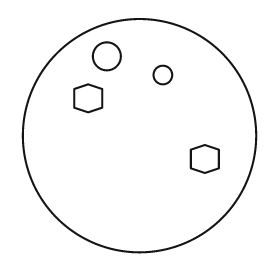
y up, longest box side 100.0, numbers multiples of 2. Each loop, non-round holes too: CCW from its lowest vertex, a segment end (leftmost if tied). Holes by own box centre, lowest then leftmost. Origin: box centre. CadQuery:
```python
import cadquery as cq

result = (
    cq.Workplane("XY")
    .moveTo(0.0, 0.0)
    .circle(50.0)
    .moveTo(28.0, -16.0)
    .lineTo(34.0, -14.0)
    .lineTo(34.0, -6.0)
    .lineTo(28.0, -4.0)
    .lineTo(22.0, -6.0)
    .lineTo(22.0, -14.0)
    .close()
    .moveTo(-22.0, 10.0)
    .lineTo(-16.0, 12.0)
    .lineTo(-16.0, 20.0)
    .lineTo(-22.0, 22.0)
    .lineTo(-28.0, 20.0)
    .lineTo(-28.0, 12.0)
    .close()
    .moveTo(10.0, 26.0)
    .circle(4.0)
    .moveTo(-14.0, 34.0)
    .circle(6.0)
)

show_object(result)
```